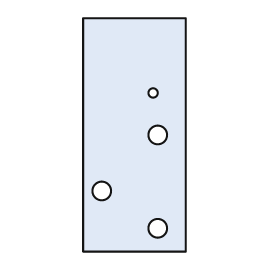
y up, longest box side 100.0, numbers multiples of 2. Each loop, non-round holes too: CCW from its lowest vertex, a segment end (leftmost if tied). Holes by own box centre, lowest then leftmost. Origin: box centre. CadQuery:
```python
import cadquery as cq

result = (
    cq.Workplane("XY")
    .moveTo(-22.0, -50.0)
    .lineTo(22.0, -50.0)
    .lineTo(22.0, 50.0)
    .lineTo(-22.0, 50.0)
    .close()
    .moveTo(10.0, -40.0)
    .circle(4.0)
    .moveTo(-14.0, -24.0)
    .circle(4.0)
    .moveTo(10.0, 0.0)
    .circle(4.0)
    .moveTo(8.0, 18.0)
    .circle(2.0)
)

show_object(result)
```